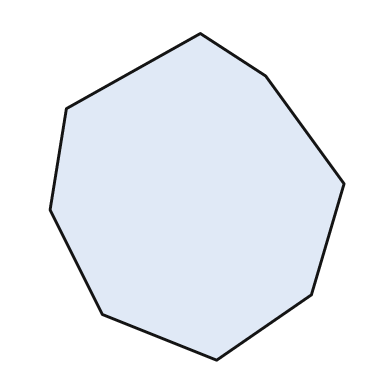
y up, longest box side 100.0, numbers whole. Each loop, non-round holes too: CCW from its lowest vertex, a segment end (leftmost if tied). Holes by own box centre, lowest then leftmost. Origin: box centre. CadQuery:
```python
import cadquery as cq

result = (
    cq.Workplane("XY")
    .moveTo(6.0, -50.0)
    .lineTo(35.0, -30.0)
    .lineTo(45.0, 4.0)
    .lineTo(21.0, 37.0)
    .lineTo(1.0, 50.0)
    .lineTo(-40.0, 27.0)
    .lineTo(-45.0, -4.0)
    .lineTo(-29.0, -36.0)
    .close()
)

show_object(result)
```